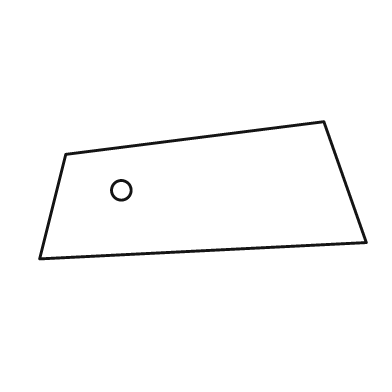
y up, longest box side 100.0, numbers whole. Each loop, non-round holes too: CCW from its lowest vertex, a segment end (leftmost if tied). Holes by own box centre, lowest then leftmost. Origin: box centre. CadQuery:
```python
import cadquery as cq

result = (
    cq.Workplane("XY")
    .moveTo(-50.0, -21.0)
    .lineTo(50.0, -16.0)
    .lineTo(37.0, 21.0)
    .lineTo(-42.0, 11.0)
    .close()
    .moveTo(-25.0, 0.0)
    .circle(3.0)
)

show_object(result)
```